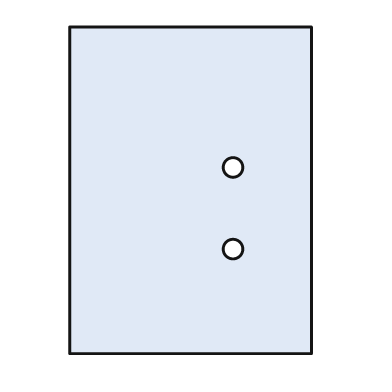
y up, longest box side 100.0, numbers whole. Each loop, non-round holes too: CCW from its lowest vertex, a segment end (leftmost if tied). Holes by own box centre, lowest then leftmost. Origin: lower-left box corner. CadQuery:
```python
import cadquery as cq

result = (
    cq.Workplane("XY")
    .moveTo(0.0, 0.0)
    .lineTo(74.0, 0.0)
    .lineTo(74.0, 100.0)
    .lineTo(0.0, 100.0)
    .close()
    .moveTo(50.0, 32.0)
    .circle(3.0)
    .moveTo(50.0, 57.0)
    .circle(3.0)
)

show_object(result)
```